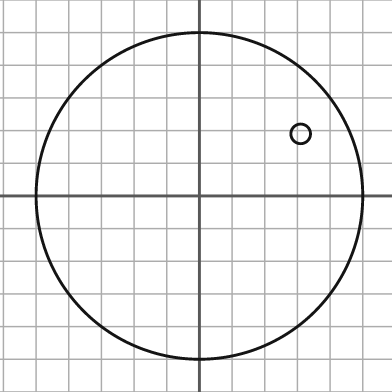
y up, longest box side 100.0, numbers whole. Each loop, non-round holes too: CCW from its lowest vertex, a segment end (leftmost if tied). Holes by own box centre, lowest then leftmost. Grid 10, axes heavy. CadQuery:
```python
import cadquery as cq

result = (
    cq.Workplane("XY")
    .moveTo(0.0, 0.0)
    .circle(50.0)
    .moveTo(31.0, 19.0)
    .circle(3.0)
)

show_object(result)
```